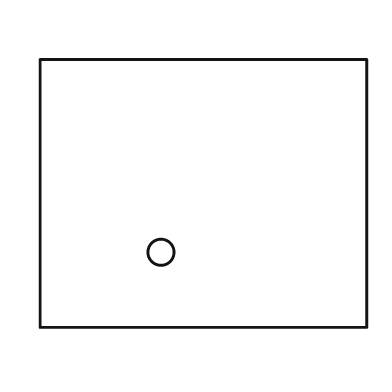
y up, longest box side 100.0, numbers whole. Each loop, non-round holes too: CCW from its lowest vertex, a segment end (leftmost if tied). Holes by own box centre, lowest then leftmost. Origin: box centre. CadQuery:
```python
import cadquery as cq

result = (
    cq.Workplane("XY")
    .moveTo(-50.0, -41.0)
    .lineTo(50.0, -41.0)
    .lineTo(50.0, 41.0)
    .lineTo(-50.0, 41.0)
    .close()
    .moveTo(-13.0, -18.0)
    .circle(4.0)
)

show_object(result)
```